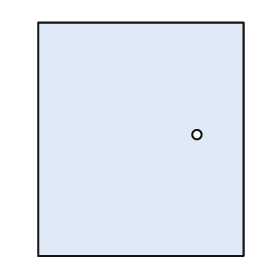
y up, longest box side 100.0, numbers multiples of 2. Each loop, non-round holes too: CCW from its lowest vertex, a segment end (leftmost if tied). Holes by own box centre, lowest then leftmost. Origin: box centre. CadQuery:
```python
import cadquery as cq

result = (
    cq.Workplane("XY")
    .moveTo(-44.0, -50.0)
    .lineTo(44.0, -50.0)
    .lineTo(44.0, 50.0)
    .lineTo(-44.0, 50.0)
    .close()
    .moveTo(24.0, 2.0)
    .circle(2.0)
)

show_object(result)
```